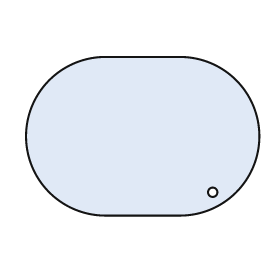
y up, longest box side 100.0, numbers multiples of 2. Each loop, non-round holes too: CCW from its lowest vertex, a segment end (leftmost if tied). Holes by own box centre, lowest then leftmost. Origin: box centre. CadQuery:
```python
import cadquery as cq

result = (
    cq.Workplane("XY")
    .moveTo(-16.0, -34.0)
    .lineTo(16.0, -34.0)
    .threePointArc((50.0, 0.0), (16.0, 34.0))
    .lineTo(-16.0, 34.0)
    .threePointArc((-50.0, 0.0), (-16.0, -34.0))
    .close()
    .moveTo(30.0, -24.0)
    .circle(2.0)
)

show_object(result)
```